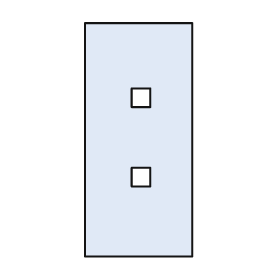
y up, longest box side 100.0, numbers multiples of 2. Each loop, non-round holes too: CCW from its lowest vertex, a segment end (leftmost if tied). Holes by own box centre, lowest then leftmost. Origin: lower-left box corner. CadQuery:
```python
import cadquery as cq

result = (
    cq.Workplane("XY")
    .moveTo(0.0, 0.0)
    .lineTo(46.0, 0.0)
    .lineTo(46.0, 100.0)
    .lineTo(0.0, 100.0)
    .close()
    .moveTo(20.0, 30.0)
    .lineTo(28.0, 30.0)
    .lineTo(28.0, 38.0)
    .lineTo(20.0, 38.0)
    .close()
    .moveTo(20.0, 64.0)
    .lineTo(28.0, 64.0)
    .lineTo(28.0, 72.0)
    .lineTo(20.0, 72.0)
    .close()
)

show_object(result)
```